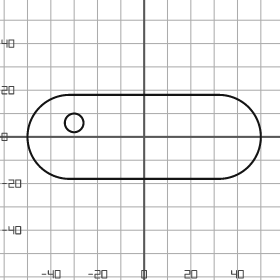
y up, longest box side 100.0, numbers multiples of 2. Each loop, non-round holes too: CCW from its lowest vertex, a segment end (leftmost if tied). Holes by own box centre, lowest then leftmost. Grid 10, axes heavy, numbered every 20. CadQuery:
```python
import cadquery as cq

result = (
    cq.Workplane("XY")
    .moveTo(-32.0, -18.0)
    .lineTo(32.0, -18.0)
    .threePointArc((50.0, 0.0), (32.0, 18.0))
    .lineTo(-32.0, 18.0)
    .threePointArc((-50.0, 0.0), (-32.0, -18.0))
    .close()
    .moveTo(-30.0, 6.0)
    .circle(4.0)
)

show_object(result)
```